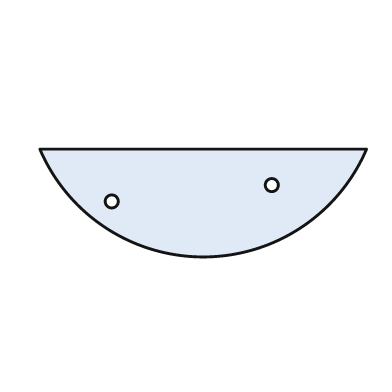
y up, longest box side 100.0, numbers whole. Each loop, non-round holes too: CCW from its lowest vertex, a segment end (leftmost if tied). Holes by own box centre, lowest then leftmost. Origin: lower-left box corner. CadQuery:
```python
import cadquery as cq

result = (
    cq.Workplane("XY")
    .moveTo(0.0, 33.0)
    .threePointArc((50.0, 0.0), (100.0, 33.0))
    .close()
    .moveTo(22.0, 17.0)
    .circle(2.0)
    .moveTo(71.0, 22.0)
    .circle(2.0)
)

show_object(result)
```